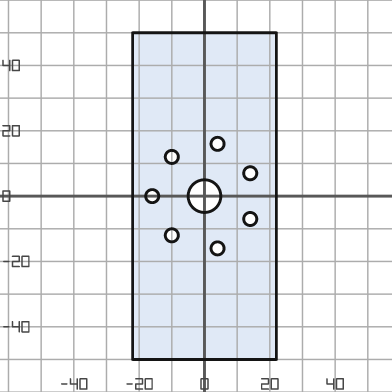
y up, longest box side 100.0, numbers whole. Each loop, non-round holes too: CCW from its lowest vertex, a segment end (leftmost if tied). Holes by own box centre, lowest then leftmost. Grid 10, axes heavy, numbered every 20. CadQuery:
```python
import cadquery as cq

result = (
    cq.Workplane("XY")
    .moveTo(-22.0, -50.0)
    .lineTo(22.0, -50.0)
    .lineTo(22.0, 50.0)
    .lineTo(-22.0, 50.0)
    .close()
    .moveTo(4.0, -16.0)
    .circle(2.0)
    .moveTo(-10.0, -12.0)
    .circle(2.0)
    .moveTo(14.0, -7.0)
    .circle(2.0)
    .moveTo(-16.0, 0.0)
    .circle(2.0)
    .moveTo(0.0, 0.0)
    .circle(5.0)
    .moveTo(14.0, 7.0)
    .circle(2.0)
    .moveTo(-10.0, 12.0)
    .circle(2.0)
    .moveTo(4.0, 16.0)
    .circle(2.0)
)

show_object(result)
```